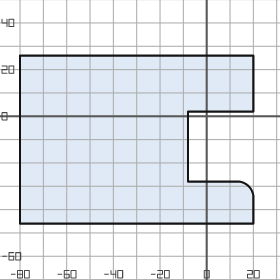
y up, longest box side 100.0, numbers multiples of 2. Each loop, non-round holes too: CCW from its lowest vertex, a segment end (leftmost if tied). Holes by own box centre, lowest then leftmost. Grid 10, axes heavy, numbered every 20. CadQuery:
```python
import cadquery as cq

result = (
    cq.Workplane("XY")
    .moveTo(-80.0, -46.0)
    .lineTo(20.0, -46.0)
    .lineTo(20.0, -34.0)
    .threePointArc((18.0, -30.0), (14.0, -28.0))
    .lineTo(-8.0, -28.0)
    .lineTo(-8.0, 2.0)
    .lineTo(20.0, 2.0)
    .lineTo(20.0, 26.0)
    .lineTo(-80.0, 26.0)
    .close()
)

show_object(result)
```